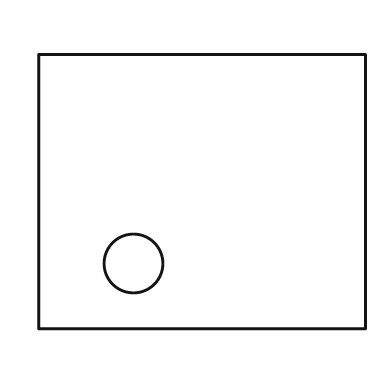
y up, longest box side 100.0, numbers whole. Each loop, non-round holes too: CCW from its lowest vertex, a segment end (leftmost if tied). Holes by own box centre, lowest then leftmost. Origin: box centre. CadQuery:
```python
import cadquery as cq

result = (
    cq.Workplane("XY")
    .moveTo(-50.0, -42.0)
    .lineTo(50.0, -42.0)
    .lineTo(50.0, 42.0)
    .lineTo(-50.0, 42.0)
    .close()
    .moveTo(-21.0, -22.0)
    .circle(9.0)
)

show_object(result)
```